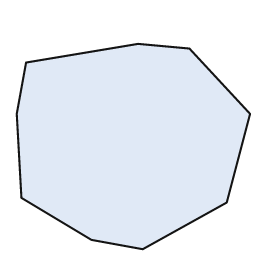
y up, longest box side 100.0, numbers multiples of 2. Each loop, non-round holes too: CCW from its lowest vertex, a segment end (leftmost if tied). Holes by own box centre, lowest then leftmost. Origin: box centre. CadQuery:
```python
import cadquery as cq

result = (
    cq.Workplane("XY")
    .moveTo(4.0, -44.0)
    .lineTo(40.0, -24.0)
    .lineTo(50.0, 14.0)
    .lineTo(24.0, 42.0)
    .lineTo(2.0, 44.0)
    .lineTo(-46.0, 36.0)
    .lineTo(-50.0, 14.0)
    .lineTo(-48.0, -22.0)
    .lineTo(-18.0, -40.0)
    .close()
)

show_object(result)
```